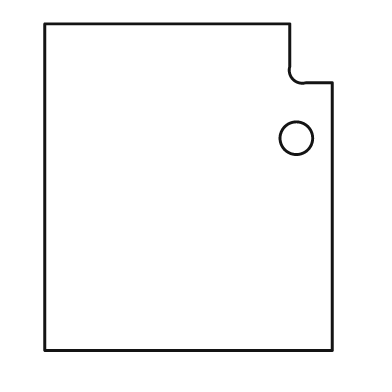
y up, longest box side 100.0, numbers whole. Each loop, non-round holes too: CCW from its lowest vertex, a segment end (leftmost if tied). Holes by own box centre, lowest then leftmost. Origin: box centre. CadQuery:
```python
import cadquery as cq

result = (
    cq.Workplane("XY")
    .moveTo(-44.0, -50.0)
    .lineTo(44.0, -50.0)
    .lineTo(44.0, 32.0)
    .lineTo(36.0, 32.0)
    .threePointArc((32.0, 33.0), (31.0, 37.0))
    .lineTo(31.0, 50.0)
    .lineTo(-44.0, 50.0)
    .close()
    .moveTo(33.0, 15.0)
    .circle(5.0)
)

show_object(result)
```